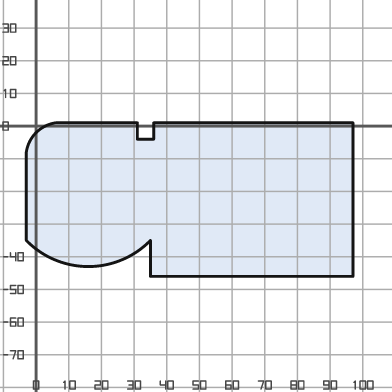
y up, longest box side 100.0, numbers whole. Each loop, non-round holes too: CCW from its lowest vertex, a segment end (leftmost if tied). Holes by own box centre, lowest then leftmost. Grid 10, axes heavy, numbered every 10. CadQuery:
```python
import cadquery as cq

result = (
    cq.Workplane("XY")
    .moveTo(35.0, -46.0)
    .lineTo(97.0, -46.0)
    .lineTo(97.0, 1.0)
    .lineTo(36.0, 1.0)
    .lineTo(36.0, -4.0)
    .lineTo(31.0, -4.0)
    .lineTo(31.0, 1.0)
    .lineTo(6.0, 1.0)
    .threePointArc((0.0, -2.0), (-3.0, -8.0))
    .lineTo(-3.0, -35.0)
    .threePointArc((16.0, -43.0), (35.0, -35.0))
    .close()
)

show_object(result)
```